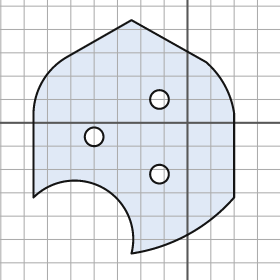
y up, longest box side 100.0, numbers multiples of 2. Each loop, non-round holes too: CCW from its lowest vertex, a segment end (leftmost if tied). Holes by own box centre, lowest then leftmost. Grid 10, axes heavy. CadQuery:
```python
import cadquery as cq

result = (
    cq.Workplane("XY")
    .moveTo(-24.0, -56.0)
    .threePointArc((0.0, -48.0), (20.0, -32.0))
    .lineTo(20.0, 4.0)
    .threePointArc((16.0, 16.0), (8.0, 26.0))
    .lineTo(-24.0, 44.0)
    .lineTo(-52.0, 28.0)
    .threePointArc((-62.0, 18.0), (-66.0, 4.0))
    .lineTo(-66.0, -32.0)
    .threePointArc((-36.0, -28.0), (-24.0, -56.0))
    .close()
    .moveTo(-12.0, -22.0)
    .circle(4.0)
    .moveTo(-40.0, -6.0)
    .circle(4.0)
    .moveTo(-12.0, 10.0)
    .circle(4.0)
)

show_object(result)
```